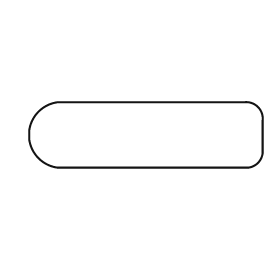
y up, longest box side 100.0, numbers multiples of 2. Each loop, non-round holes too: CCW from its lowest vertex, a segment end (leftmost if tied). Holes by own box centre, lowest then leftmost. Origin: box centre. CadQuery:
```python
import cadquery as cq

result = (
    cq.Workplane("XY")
    .moveTo(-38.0, -14.0)
    .lineTo(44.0, -14.0)
    .threePointArc((48.0, -12.0), (50.0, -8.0))
    .lineTo(50.0, 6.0)
    .threePointArc((48.0, 12.0), (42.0, 14.0))
    .lineTo(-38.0, 14.0)
    .threePointArc((-46.0, 10.0), (-50.0, 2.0))
    .lineTo(-50.0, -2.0)
    .threePointArc((-46.0, -10.0), (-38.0, -14.0))
    .close()
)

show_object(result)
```